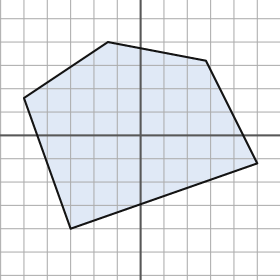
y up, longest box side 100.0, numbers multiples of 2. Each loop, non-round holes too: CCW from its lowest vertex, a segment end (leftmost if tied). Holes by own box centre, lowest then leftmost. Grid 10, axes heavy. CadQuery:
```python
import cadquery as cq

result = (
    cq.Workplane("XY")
    .moveTo(-30.0, -40.0)
    .lineTo(50.0, -12.0)
    .lineTo(28.0, 32.0)
    .lineTo(-14.0, 40.0)
    .lineTo(-50.0, 16.0)
    .close()
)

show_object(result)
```